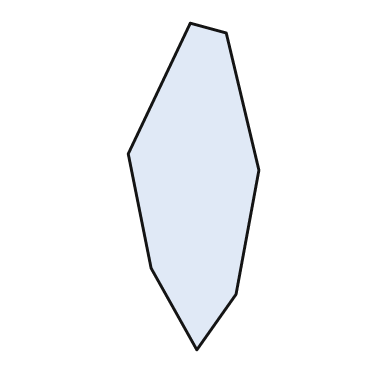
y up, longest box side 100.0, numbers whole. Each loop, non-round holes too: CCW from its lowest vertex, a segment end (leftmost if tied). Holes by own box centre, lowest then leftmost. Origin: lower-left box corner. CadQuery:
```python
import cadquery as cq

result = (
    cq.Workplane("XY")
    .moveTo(21.0, 0.0)
    .lineTo(33.0, 17.0)
    .lineTo(40.0, 55.0)
    .lineTo(30.0, 97.0)
    .lineTo(19.0, 100.0)
    .lineTo(0.0, 60.0)
    .lineTo(7.0, 25.0)
    .close()
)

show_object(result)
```